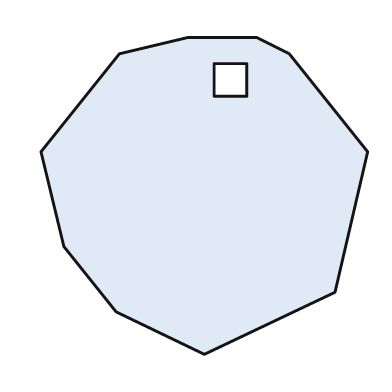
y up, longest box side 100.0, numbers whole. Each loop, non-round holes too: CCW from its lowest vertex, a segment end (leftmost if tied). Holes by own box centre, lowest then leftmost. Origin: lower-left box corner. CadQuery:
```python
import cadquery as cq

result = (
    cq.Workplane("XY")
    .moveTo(50.0, 0.0)
    .lineTo(90.0, 19.0)
    .lineTo(100.0, 62.0)
    .lineTo(76.0, 92.0)
    .lineTo(66.0, 97.0)
    .lineTo(45.0, 97.0)
    .lineTo(24.0, 92.0)
    .lineTo(0.0, 62.0)
    .lineTo(7.0, 33.0)
    .lineTo(23.0, 13.0)
    .close()
    .moveTo(53.0, 79.0)
    .lineTo(63.0, 79.0)
    .lineTo(63.0, 89.0)
    .lineTo(53.0, 89.0)
    .close()
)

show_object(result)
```